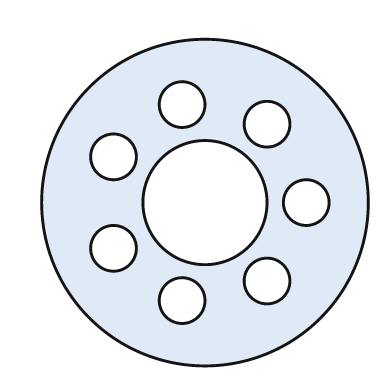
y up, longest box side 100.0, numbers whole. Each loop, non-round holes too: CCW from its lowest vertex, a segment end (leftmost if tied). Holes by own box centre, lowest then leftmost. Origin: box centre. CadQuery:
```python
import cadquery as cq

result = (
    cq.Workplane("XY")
    .moveTo(0.0, 0.0)
    .circle(50.0)
    .moveTo(-7.0, -30.0)
    .circle(7.0)
    .moveTo(19.0, -24.0)
    .circle(7.0)
    .moveTo(-28.0, -14.0)
    .circle(7.0)
    .moveTo(0.0, 0.0)
    .circle(19.0)
    .moveTo(31.0, 0.0)
    .circle(7.0)
    .moveTo(-28.0, 14.0)
    .circle(7.0)
    .moveTo(19.0, 24.0)
    .circle(7.0)
    .moveTo(-7.0, 30.0)
    .circle(7.0)
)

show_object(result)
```